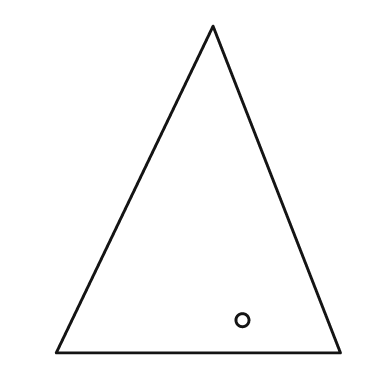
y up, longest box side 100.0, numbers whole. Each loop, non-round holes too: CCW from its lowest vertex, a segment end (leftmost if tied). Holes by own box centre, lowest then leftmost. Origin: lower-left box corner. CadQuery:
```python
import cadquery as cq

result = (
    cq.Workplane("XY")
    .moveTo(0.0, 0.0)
    .lineTo(87.0, 0.0)
    .lineTo(48.0, 100.0)
    .close()
    .moveTo(57.0, 10.0)
    .circle(2.0)
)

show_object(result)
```